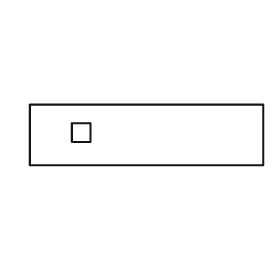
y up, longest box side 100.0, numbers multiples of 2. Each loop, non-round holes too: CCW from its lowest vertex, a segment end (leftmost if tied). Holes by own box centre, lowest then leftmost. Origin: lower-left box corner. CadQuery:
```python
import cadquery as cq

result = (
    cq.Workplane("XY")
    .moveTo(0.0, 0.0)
    .lineTo(100.0, 0.0)
    .lineTo(100.0, 26.0)
    .lineTo(0.0, 26.0)
    .close()
    .moveTo(18.0, 10.0)
    .lineTo(26.0, 10.0)
    .lineTo(26.0, 18.0)
    .lineTo(18.0, 18.0)
    .close()
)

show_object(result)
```